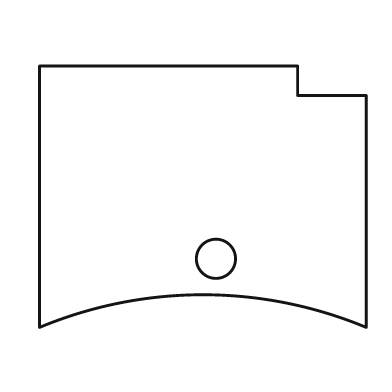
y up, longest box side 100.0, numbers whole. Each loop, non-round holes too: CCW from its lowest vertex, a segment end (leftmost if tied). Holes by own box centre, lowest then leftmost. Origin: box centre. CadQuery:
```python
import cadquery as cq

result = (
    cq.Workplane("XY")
    .moveTo(-50.0, -40.0)
    .threePointArc((0.0, -30.0), (50.0, -40.0))
    .lineTo(50.0, 31.0)
    .lineTo(29.0, 31.0)
    .lineTo(29.0, 40.0)
    .lineTo(-50.0, 40.0)
    .close()
    .moveTo(4.0, -19.0)
    .circle(6.0)
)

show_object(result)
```